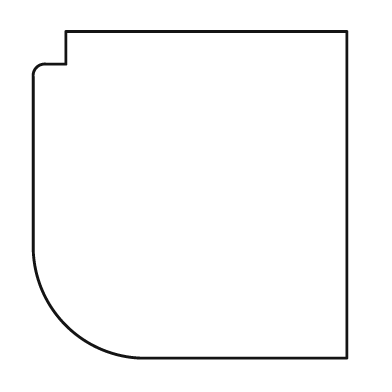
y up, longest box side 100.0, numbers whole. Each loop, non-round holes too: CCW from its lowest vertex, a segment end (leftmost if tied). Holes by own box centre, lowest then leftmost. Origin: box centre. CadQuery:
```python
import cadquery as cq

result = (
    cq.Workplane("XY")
    .moveTo(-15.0, -50.0)
    .lineTo(48.0, -50.0)
    .lineTo(48.0, 50.0)
    .lineTo(-38.0, 50.0)
    .lineTo(-38.0, 40.0)
    .lineTo(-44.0, 40.0)
    .threePointArc((-47.0, 39.0), (-48.0, 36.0))
    .lineTo(-48.0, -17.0)
    .threePointArc((-38.0, -40.0), (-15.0, -50.0))
    .close()
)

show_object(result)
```